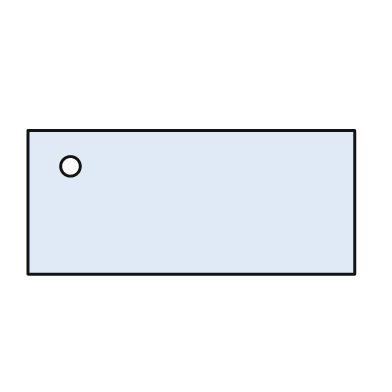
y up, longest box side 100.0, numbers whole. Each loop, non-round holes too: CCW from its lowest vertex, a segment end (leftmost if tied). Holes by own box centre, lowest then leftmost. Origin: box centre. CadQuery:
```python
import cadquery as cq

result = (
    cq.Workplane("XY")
    .moveTo(-50.0, -22.0)
    .lineTo(50.0, -22.0)
    .lineTo(50.0, 22.0)
    .lineTo(-50.0, 22.0)
    .close()
    .moveTo(-37.0, 11.0)
    .circle(3.0)
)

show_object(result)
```